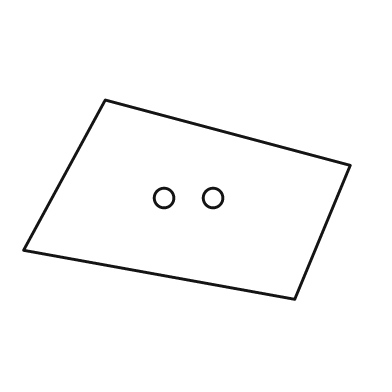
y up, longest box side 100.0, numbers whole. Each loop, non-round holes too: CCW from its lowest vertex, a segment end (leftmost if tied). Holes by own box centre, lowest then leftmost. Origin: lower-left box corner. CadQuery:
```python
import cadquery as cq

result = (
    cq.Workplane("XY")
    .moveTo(83.0, 0.0)
    .lineTo(100.0, 41.0)
    .lineTo(25.0, 61.0)
    .lineTo(0.0, 15.0)
    .close()
    .moveTo(43.0, 31.0)
    .circle(3.0)
    .moveTo(58.0, 31.0)
    .circle(3.0)
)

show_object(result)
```